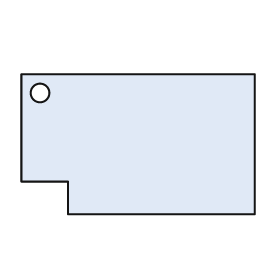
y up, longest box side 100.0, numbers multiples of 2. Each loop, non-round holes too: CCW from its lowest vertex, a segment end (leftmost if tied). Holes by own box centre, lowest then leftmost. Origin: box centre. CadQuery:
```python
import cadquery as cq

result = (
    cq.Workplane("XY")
    .moveTo(-30.0, -30.0)
    .lineTo(50.0, -30.0)
    .lineTo(50.0, 30.0)
    .lineTo(-50.0, 30.0)
    .lineTo(-50.0, -16.0)
    .lineTo(-30.0, -16.0)
    .close()
    .moveTo(-42.0, 22.0)
    .circle(4.0)
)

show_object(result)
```